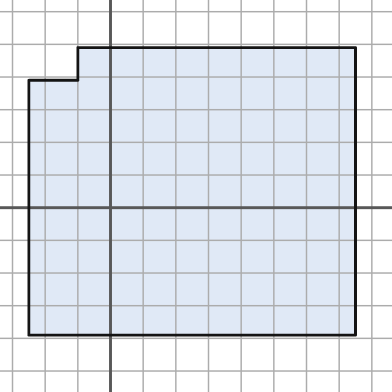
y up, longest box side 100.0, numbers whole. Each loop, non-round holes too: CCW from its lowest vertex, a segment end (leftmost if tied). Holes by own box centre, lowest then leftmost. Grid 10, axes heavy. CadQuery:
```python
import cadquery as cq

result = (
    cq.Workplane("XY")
    .moveTo(-25.0, -39.0)
    .lineTo(75.0, -39.0)
    .lineTo(75.0, 49.0)
    .lineTo(-10.0, 49.0)
    .lineTo(-10.0, 39.0)
    .lineTo(-25.0, 39.0)
    .close()
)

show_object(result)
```